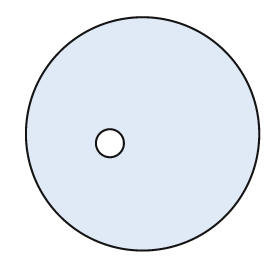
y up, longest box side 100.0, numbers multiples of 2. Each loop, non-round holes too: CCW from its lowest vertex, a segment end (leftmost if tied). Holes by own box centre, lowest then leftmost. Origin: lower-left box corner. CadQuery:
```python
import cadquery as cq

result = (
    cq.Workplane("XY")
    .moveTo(50.0, 50.0)
    .circle(50.0)
    .moveTo(36.0, 46.0)
    .circle(6.0)
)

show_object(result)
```